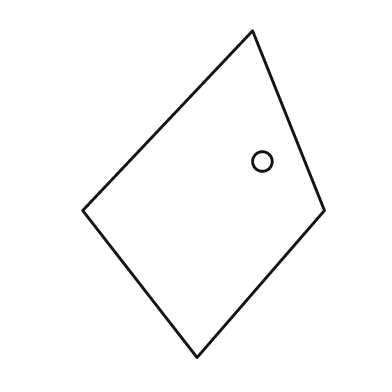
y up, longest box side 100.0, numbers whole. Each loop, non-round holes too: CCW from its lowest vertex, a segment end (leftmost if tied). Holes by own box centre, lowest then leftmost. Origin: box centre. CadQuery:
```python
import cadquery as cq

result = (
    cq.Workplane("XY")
    .moveTo(-2.0, -50.0)
    .lineTo(37.0, -5.0)
    .lineTo(15.0, 50.0)
    .lineTo(-37.0, -5.0)
    .close()
    .moveTo(18.0, 10.0)
    .circle(3.0)
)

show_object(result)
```